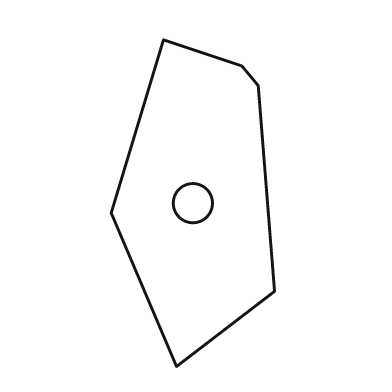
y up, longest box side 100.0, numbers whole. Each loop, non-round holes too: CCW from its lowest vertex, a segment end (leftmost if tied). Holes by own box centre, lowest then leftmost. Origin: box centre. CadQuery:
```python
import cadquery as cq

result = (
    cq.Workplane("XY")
    .moveTo(-5.0, -50.0)
    .lineTo(25.0, -27.0)
    .lineTo(20.0, 36.0)
    .lineTo(15.0, 42.0)
    .lineTo(-9.0, 50.0)
    .lineTo(-25.0, -3.0)
    .close()
    .moveTo(0.0, 0.0)
    .circle(6.0)
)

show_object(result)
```